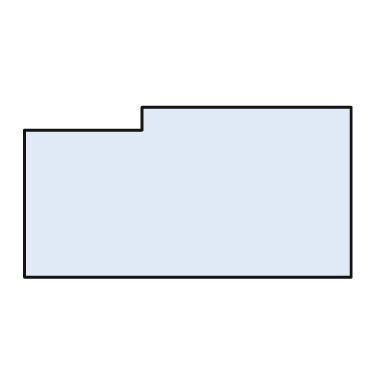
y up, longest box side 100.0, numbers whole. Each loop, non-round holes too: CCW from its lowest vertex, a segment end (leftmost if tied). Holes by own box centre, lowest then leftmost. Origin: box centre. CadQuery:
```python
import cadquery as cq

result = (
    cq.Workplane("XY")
    .moveTo(-50.0, -26.0)
    .lineTo(50.0, -26.0)
    .lineTo(50.0, 26.0)
    .lineTo(-14.0, 26.0)
    .lineTo(-14.0, 19.0)
    .lineTo(-50.0, 19.0)
    .close()
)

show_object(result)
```